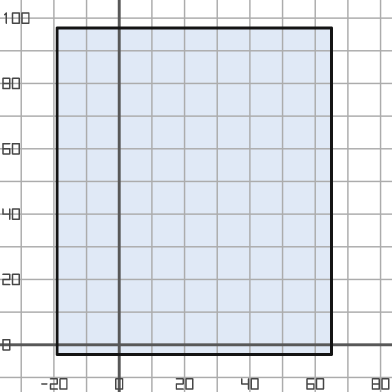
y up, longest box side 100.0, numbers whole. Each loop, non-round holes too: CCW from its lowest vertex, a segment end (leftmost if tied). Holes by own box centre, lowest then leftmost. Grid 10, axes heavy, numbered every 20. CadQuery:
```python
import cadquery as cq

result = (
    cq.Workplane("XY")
    .moveTo(-19.0, -3.0)
    .lineTo(65.0, -3.0)
    .lineTo(65.0, 97.0)
    .lineTo(-19.0, 97.0)
    .close()
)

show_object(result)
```